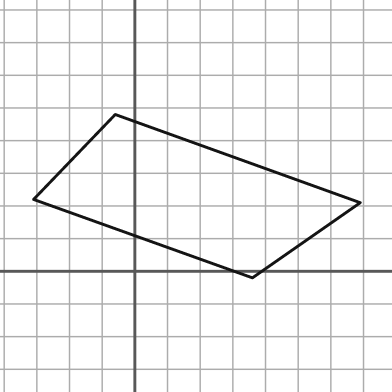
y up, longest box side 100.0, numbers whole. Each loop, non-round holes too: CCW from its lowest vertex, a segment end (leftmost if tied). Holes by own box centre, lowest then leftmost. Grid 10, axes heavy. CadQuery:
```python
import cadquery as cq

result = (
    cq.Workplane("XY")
    .moveTo(36.0, -2.0)
    .lineTo(69.0, 21.0)
    .lineTo(-6.0, 48.0)
    .lineTo(-31.0, 22.0)
    .close()
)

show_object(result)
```